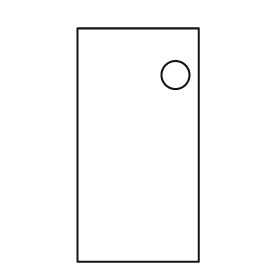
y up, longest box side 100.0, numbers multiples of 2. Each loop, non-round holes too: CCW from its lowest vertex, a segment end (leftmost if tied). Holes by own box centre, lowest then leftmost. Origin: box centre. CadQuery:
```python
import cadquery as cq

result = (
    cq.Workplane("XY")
    .moveTo(-26.0, -50.0)
    .lineTo(26.0, -50.0)
    .lineTo(26.0, 50.0)
    .lineTo(-26.0, 50.0)
    .close()
    .moveTo(16.0, 30.0)
    .circle(6.0)
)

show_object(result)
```